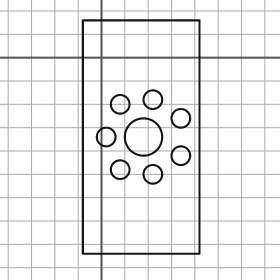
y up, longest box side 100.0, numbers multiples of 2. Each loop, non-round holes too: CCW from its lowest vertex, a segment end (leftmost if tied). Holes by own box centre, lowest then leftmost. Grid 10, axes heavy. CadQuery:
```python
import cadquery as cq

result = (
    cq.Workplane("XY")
    .moveTo(-8.0, -84.0)
    .lineTo(42.0, -84.0)
    .lineTo(42.0, 16.0)
    .lineTo(-8.0, 16.0)
    .close()
    .moveTo(22.0, -50.0)
    .circle(4.0)
    .moveTo(8.0, -48.0)
    .circle(4.0)
    .moveTo(34.0, -42.0)
    .circle(4.0)
    .moveTo(2.0, -34.0)
    .circle(4.0)
    .moveTo(18.0, -34.0)
    .circle(8.0)
    .moveTo(34.0, -26.0)
    .circle(4.0)
    .moveTo(8.0, -20.0)
    .circle(4.0)
    .moveTo(22.0, -18.0)
    .circle(4.0)
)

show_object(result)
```